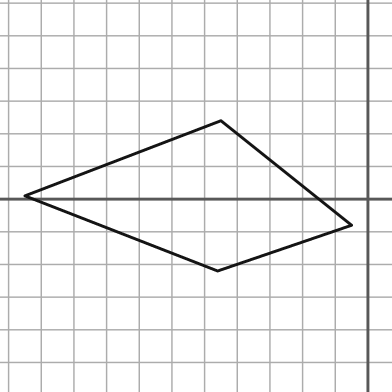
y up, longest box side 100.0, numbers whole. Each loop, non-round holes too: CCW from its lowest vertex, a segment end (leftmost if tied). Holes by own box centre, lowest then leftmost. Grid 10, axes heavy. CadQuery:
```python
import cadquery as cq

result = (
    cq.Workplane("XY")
    .moveTo(-46.0, -22.0)
    .lineTo(-5.0, -8.0)
    .lineTo(-45.0, 24.0)
    .lineTo(-105.0, 1.0)
    .close()
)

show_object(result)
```